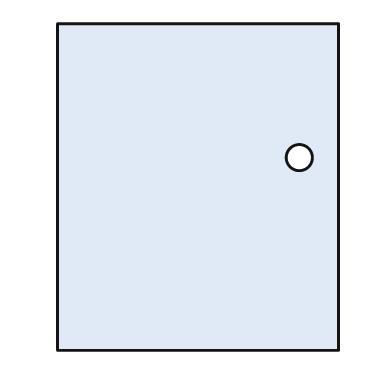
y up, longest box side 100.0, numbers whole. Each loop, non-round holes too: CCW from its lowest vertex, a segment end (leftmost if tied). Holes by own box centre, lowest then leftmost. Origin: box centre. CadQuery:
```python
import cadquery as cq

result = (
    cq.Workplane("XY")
    .moveTo(-43.0, -50.0)
    .lineTo(43.0, -50.0)
    .lineTo(43.0, 50.0)
    .lineTo(-43.0, 50.0)
    .close()
    .moveTo(31.0, 9.0)
    .circle(4.0)
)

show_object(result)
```